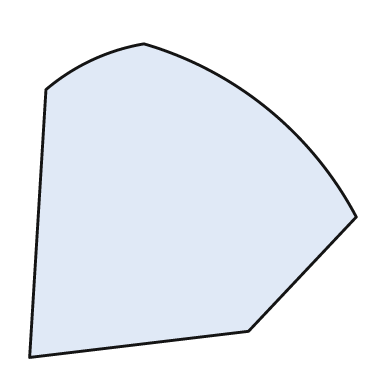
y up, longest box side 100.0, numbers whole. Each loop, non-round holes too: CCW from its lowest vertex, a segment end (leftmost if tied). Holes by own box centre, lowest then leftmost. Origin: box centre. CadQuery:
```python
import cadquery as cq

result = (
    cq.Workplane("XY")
    .moveTo(-50.0, -48.0)
    .lineTo(17.0, -40.0)
    .lineTo(50.0, -5.0)
    .threePointArc((23.0, 28.0), (-15.0, 48.0))
    .threePointArc((-31.0, 43.0), (-45.0, 34.0))
    .close()
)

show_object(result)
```